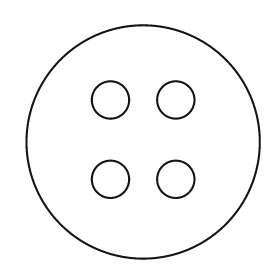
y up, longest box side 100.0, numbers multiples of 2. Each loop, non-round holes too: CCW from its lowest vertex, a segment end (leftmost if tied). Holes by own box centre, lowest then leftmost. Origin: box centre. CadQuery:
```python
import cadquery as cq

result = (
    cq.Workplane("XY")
    .moveTo(0.0, 0.0)
    .circle(50.0)
    .moveTo(-14.0, -16.0)
    .circle(8.0)
    .moveTo(14.0, -16.0)
    .circle(8.0)
    .moveTo(-14.0, 18.0)
    .circle(8.0)
    .moveTo(14.0, 18.0)
    .circle(8.0)
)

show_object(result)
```